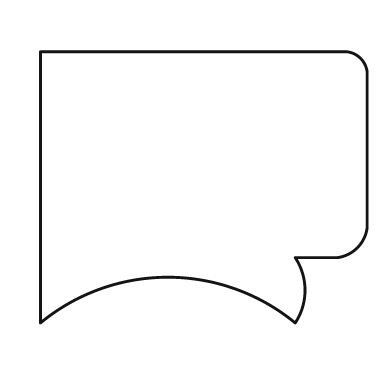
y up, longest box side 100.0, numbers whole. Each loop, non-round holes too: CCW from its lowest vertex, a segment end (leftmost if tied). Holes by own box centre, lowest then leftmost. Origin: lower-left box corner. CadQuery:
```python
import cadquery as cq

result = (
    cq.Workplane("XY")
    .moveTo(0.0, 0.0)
    .threePointArc((39.0, 14.0), (78.0, 0.0))
    .threePointArc((81.0, 10.0), (78.0, 20.0))
    .lineTo(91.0, 20.0)
    .threePointArc((97.0, 23.0), (100.0, 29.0))
    .lineTo(100.0, 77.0)
    .threePointArc((98.0, 81.0), (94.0, 83.0))
    .lineTo(0.0, 83.0)
    .close()
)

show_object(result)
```